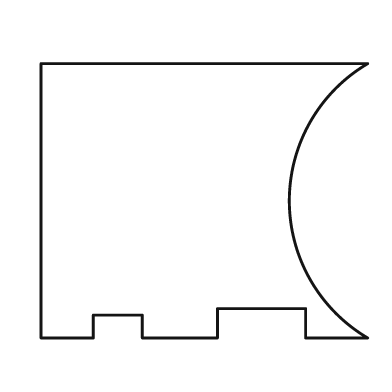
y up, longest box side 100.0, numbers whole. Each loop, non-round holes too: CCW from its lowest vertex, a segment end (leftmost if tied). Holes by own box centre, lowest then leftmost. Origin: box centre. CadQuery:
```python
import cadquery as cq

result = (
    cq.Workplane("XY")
    .moveTo(-50.0, -42.0)
    .lineTo(-34.0, -42.0)
    .lineTo(-34.0, -35.0)
    .lineTo(-19.0, -35.0)
    .lineTo(-19.0, -42.0)
    .lineTo(4.0, -42.0)
    .lineTo(4.0, -33.0)
    .lineTo(31.0, -33.0)
    .lineTo(31.0, -42.0)
    .lineTo(50.0, -42.0)
    .threePointArc((26.0, 0.0), (50.0, 42.0))
    .lineTo(-50.0, 42.0)
    .close()
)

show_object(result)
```